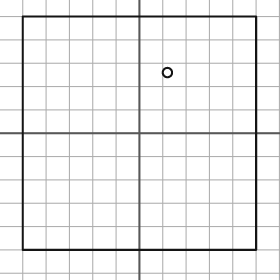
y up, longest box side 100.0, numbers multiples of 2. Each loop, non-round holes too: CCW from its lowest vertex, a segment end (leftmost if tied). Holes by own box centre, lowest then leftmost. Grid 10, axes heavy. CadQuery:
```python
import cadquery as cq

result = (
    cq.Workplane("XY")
    .moveTo(-50.0, -50.0)
    .lineTo(50.0, -50.0)
    .lineTo(50.0, 50.0)
    .lineTo(-50.0, 50.0)
    .close()
    .moveTo(12.0, 26.0)
    .circle(2.0)
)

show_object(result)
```